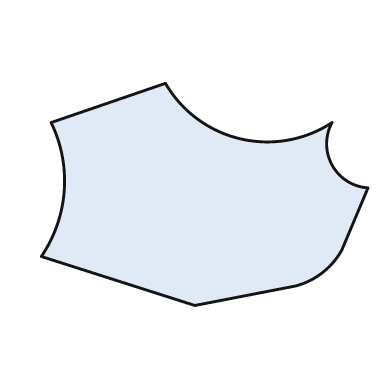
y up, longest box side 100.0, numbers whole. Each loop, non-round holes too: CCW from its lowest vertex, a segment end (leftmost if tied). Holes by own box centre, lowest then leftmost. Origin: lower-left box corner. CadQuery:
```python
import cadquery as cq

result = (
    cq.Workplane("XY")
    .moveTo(47.0, 0.0)
    .lineTo(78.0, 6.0)
    .threePointArc((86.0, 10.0), (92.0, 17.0))
    .lineTo(100.0, 36.0)
    .threePointArc((89.0, 43.0), (89.0, 56.0))
    .threePointArc((61.0, 51.0), (38.0, 68.0))
    .lineTo(3.0, 56.0)
    .threePointArc((7.0, 35.0), (0.0, 15.0))
    .close()
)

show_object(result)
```